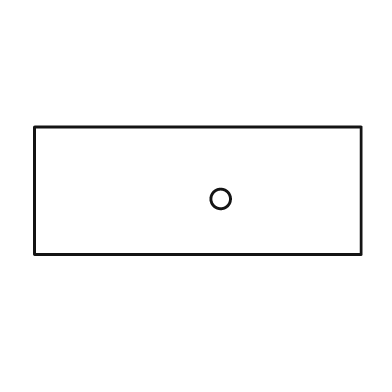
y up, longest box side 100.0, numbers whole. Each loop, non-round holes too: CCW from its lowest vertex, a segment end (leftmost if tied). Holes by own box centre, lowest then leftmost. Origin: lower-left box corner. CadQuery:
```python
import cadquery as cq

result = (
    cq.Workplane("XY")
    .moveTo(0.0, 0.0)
    .lineTo(100.0, 0.0)
    .lineTo(100.0, 39.0)
    .lineTo(0.0, 39.0)
    .close()
    .moveTo(57.0, 17.0)
    .circle(3.0)
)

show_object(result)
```